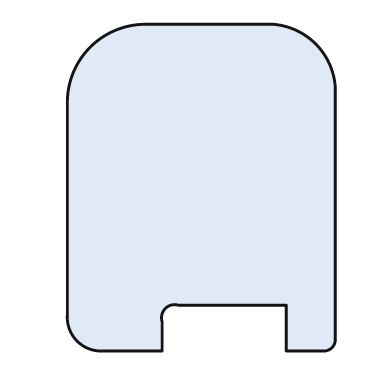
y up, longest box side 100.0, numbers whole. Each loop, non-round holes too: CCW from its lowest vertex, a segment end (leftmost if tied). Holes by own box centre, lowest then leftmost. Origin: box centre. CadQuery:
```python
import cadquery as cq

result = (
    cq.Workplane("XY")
    .moveTo(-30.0, -50.0)
    .lineTo(-12.0, -50.0)
    .lineTo(-12.0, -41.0)
    .threePointArc((-11.0, -37.0), (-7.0, -36.0))
    .lineTo(26.0, -36.0)
    .lineTo(26.0, -50.0)
    .lineTo(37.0, -50.0)
    .threePointArc((40.0, -49.0), (41.0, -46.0))
    .lineTo(41.0, 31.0)
    .threePointArc((35.0, 44.0), (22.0, 50.0))
    .lineTo(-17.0, 50.0)
    .threePointArc((-34.0, 43.0), (-41.0, 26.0))
    .lineTo(-41.0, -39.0)
    .threePointArc((-38.0, -47.0), (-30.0, -50.0))
    .close()
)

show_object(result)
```